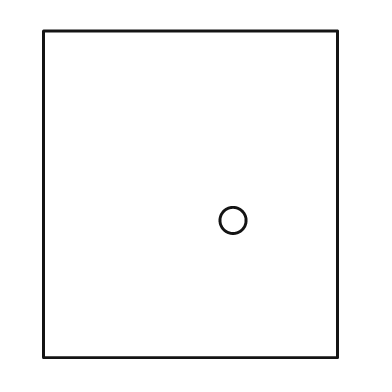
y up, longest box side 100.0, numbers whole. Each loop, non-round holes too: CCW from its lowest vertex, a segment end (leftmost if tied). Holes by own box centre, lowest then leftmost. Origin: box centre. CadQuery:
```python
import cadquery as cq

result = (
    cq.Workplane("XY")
    .moveTo(-45.0, -50.0)
    .lineTo(45.0, -50.0)
    .lineTo(45.0, 50.0)
    .lineTo(-45.0, 50.0)
    .close()
    .moveTo(13.0, -8.0)
    .circle(4.0)
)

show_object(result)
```